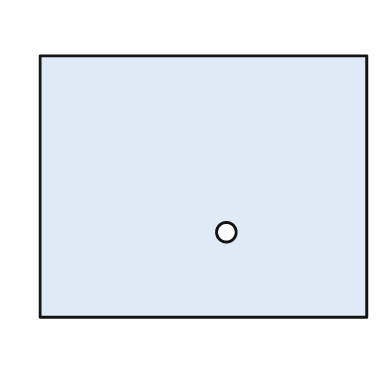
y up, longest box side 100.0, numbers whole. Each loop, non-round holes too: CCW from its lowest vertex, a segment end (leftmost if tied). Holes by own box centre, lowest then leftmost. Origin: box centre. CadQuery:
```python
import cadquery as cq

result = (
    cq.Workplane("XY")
    .moveTo(-50.0, -40.0)
    .lineTo(50.0, -40.0)
    .lineTo(50.0, 40.0)
    .lineTo(-50.0, 40.0)
    .close()
    .moveTo(7.0, -14.0)
    .circle(3.0)
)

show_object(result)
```